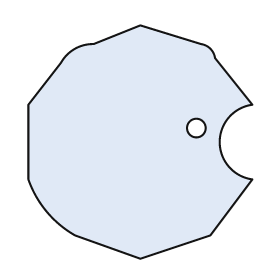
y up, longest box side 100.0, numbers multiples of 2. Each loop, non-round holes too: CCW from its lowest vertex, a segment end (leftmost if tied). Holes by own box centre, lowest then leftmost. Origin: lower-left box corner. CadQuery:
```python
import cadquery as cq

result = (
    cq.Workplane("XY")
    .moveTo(48.0, 0.0)
    .lineTo(78.0, 10.0)
    .lineTo(96.0, 34.0)
    .threePointArc((82.0, 50.0), (96.0, 66.0))
    .lineTo(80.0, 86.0)
    .threePointArc((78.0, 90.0), (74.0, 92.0))
    .lineTo(48.0, 100.0)
    .lineTo(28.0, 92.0)
    .threePointArc((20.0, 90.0), (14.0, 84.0))
    .lineTo(0.0, 66.0)
    .lineTo(0.0, 34.0)
    .threePointArc((8.0, 20.0), (20.0, 10.0))
    .close()
    .moveTo(72.0, 56.0)
    .circle(4.0)
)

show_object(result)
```